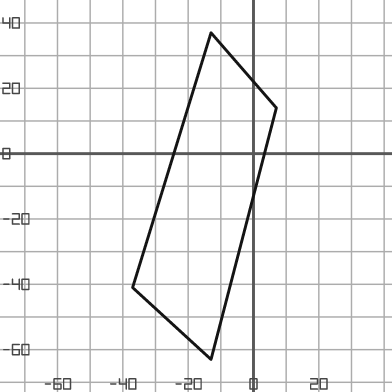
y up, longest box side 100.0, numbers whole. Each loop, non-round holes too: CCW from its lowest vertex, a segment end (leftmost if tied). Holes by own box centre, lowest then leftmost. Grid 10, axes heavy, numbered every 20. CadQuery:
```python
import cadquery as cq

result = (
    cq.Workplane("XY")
    .moveTo(-13.0, -63.0)
    .lineTo(7.0, 14.0)
    .lineTo(-13.0, 37.0)
    .lineTo(-37.0, -41.0)
    .close()
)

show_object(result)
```